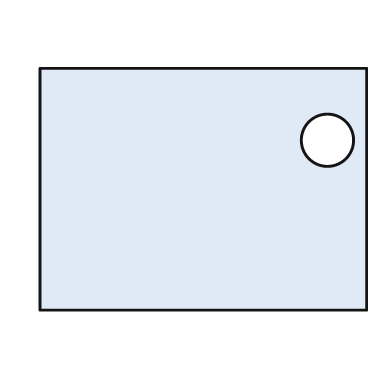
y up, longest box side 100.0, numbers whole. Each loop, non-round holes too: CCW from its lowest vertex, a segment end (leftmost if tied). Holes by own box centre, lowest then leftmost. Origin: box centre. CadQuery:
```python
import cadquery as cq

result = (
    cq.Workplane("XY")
    .moveTo(-50.0, -37.0)
    .lineTo(50.0, -37.0)
    .lineTo(50.0, 37.0)
    .lineTo(-50.0, 37.0)
    .close()
    .moveTo(38.0, 15.0)
    .circle(8.0)
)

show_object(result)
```